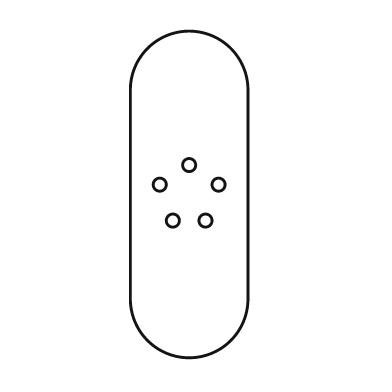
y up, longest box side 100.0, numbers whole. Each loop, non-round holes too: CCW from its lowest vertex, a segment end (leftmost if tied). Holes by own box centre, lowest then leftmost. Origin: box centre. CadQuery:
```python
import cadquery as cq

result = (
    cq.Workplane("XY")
    .moveTo(-18.0, -32.0)
    .threePointArc((0.0, -50.0), (18.0, -32.0))
    .lineTo(18.0, 32.0)
    .threePointArc((0.0, 50.0), (-18.0, 32.0))
    .close()
    .moveTo(-5.0, -8.0)
    .circle(2.0)
    .moveTo(5.0, -8.0)
    .circle(2.0)
    .moveTo(-9.0, 3.0)
    .circle(2.0)
    .moveTo(9.0, 3.0)
    .circle(2.0)
    .moveTo(0.0, 9.0)
    .circle(2.0)
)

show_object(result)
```